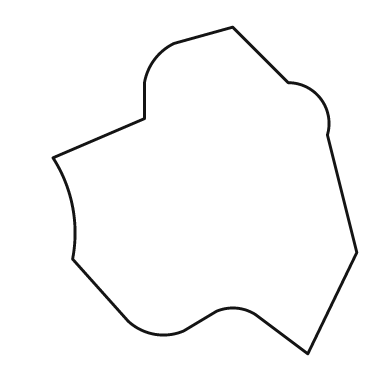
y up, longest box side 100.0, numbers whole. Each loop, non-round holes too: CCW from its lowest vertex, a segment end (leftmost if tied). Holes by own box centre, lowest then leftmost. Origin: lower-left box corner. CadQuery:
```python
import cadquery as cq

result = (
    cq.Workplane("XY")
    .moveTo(78.0, 0.0)
    .lineTo(93.0, 31.0)
    .lineTo(84.0, 67.0)
    .threePointArc((82.0, 78.0), (72.0, 83.0))
    .lineTo(55.0, 100.0)
    .lineTo(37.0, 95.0)
    .threePointArc((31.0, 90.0), (28.0, 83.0))
    .lineTo(28.0, 72.0)
    .lineTo(0.0, 60.0)
    .threePointArc((6.0, 45.0), (6.0, 29.0))
    .lineTo(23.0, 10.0)
    .threePointArc((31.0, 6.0), (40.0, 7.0))
    .lineTo(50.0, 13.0)
    .threePointArc((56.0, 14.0), (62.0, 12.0))
    .close()
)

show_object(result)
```